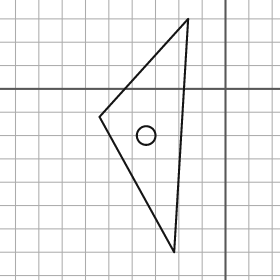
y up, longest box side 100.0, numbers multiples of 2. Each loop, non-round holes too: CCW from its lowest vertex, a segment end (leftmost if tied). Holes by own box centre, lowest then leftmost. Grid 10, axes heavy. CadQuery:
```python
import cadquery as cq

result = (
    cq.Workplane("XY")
    .moveTo(-22.0, -70.0)
    .lineTo(-16.0, 30.0)
    .lineTo(-54.0, -12.0)
    .close()
    .moveTo(-34.0, -20.0)
    .circle(4.0)
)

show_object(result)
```